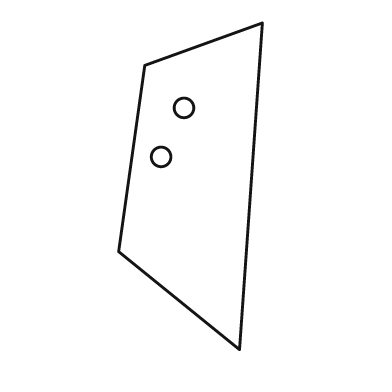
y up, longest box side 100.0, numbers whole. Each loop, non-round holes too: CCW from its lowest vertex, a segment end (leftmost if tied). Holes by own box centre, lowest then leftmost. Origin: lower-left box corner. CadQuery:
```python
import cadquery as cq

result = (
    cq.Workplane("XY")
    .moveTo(37.0, 0.0)
    .lineTo(44.0, 100.0)
    .lineTo(8.0, 87.0)
    .lineTo(0.0, 30.0)
    .close()
    .moveTo(13.0, 59.0)
    .circle(3.0)
    .moveTo(20.0, 74.0)
    .circle(3.0)
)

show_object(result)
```